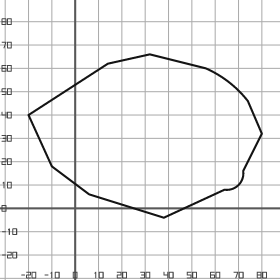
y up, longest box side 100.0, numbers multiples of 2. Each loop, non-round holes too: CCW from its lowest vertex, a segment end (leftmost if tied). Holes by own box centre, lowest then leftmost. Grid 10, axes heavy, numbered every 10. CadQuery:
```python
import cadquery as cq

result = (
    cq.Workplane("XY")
    .moveTo(38.0, -4.0)
    .lineTo(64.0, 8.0)
    .threePointArc((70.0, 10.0), (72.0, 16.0))
    .lineTo(80.0, 32.0)
    .lineTo(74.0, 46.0)
    .threePointArc((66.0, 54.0), (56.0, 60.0))
    .lineTo(32.0, 66.0)
    .lineTo(14.0, 62.0)
    .lineTo(-20.0, 40.0)
    .lineTo(-10.0, 18.0)
    .lineTo(6.0, 6.0)
    .close()
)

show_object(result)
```